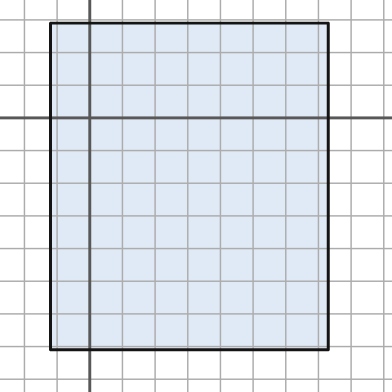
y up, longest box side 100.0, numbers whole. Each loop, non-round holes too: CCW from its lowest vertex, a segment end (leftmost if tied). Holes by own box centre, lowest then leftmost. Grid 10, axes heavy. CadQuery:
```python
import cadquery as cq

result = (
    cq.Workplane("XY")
    .moveTo(-12.0, -71.0)
    .lineTo(73.0, -71.0)
    .lineTo(73.0, 29.0)
    .lineTo(-12.0, 29.0)
    .close()
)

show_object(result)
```